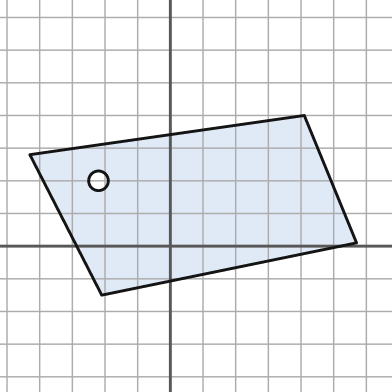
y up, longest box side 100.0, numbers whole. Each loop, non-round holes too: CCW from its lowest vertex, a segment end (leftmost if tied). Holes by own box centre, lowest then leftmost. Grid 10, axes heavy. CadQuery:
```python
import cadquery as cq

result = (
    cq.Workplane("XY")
    .moveTo(-21.0, -15.0)
    .lineTo(57.0, 1.0)
    .lineTo(41.0, 40.0)
    .lineTo(-43.0, 28.0)
    .close()
    .moveTo(-22.0, 20.0)
    .circle(3.0)
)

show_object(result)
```